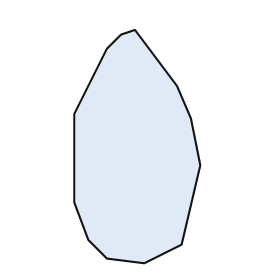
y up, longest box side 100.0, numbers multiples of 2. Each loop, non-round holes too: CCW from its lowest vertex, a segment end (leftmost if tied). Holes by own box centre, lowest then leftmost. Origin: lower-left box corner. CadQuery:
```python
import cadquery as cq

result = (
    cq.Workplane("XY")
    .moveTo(30.0, 0.0)
    .lineTo(46.0, 8.0)
    .lineTo(54.0, 42.0)
    .lineTo(50.0, 62.0)
    .lineTo(44.0, 76.0)
    .lineTo(26.0, 100.0)
    .lineTo(20.0, 98.0)
    .lineTo(14.0, 92.0)
    .lineTo(0.0, 64.0)
    .lineTo(0.0, 26.0)
    .lineTo(6.0, 10.0)
    .lineTo(14.0, 2.0)
    .close()
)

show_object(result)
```